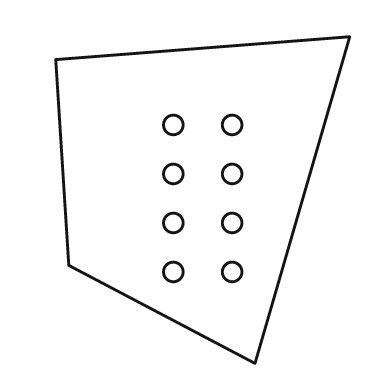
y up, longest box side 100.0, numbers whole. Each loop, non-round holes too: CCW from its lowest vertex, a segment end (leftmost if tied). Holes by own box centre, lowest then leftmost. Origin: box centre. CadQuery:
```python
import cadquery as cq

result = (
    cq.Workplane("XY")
    .moveTo(16.0, -50.0)
    .lineTo(45.0, 50.0)
    .lineTo(-45.0, 43.0)
    .lineTo(-41.0, -20.0)
    .close()
    .moveTo(-9.0, -22.0)
    .circle(3.0)
    .moveTo(9.0, -22.0)
    .circle(3.0)
    .moveTo(-9.0, -7.0)
    .circle(3.0)
    .moveTo(9.0, -7.0)
    .circle(3.0)
    .moveTo(-9.0, 8.0)
    .circle(3.0)
    .moveTo(9.0, 8.0)
    .circle(3.0)
    .moveTo(-9.0, 23.0)
    .circle(3.0)
    .moveTo(9.0, 23.0)
    .circle(3.0)
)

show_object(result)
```